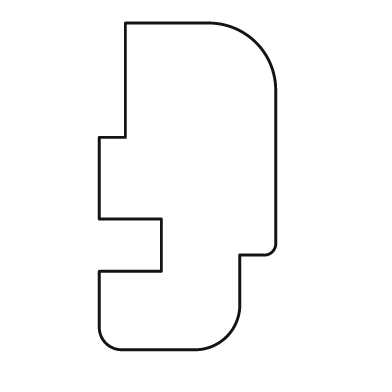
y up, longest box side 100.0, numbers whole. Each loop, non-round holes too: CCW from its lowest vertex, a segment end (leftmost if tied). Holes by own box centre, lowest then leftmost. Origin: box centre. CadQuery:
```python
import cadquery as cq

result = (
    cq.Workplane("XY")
    .moveTo(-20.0, -50.0)
    .lineTo(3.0, -50.0)
    .threePointArc((12.0, -46.0), (16.0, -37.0))
    .lineTo(16.0, -21.0)
    .lineTo(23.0, -21.0)
    .threePointArc((26.0, -20.0), (27.0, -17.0))
    .lineTo(27.0, 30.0)
    .threePointArc((21.0, 44.0), (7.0, 50.0))
    .lineTo(-19.0, 50.0)
    .lineTo(-19.0, 15.0)
    .lineTo(-27.0, 15.0)
    .lineTo(-27.0, -10.0)
    .lineTo(-8.0, -10.0)
    .lineTo(-8.0, -26.0)
    .lineTo(-27.0, -26.0)
    .lineTo(-27.0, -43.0)
    .threePointArc((-25.0, -48.0), (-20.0, -50.0))
    .close()
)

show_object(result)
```